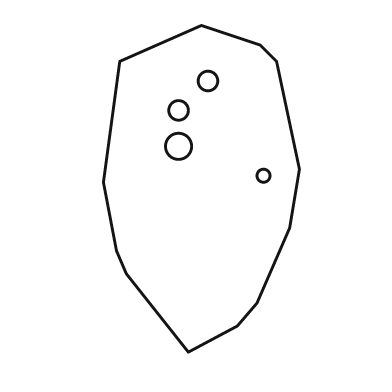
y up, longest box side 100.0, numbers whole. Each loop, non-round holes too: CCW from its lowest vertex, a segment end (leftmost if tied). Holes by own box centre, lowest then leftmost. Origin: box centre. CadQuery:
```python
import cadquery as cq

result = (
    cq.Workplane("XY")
    .moveTo(-4.0, -50.0)
    .lineTo(11.0, -42.0)
    .lineTo(17.0, -35.0)
    .lineTo(27.0, -12.0)
    .lineTo(30.0, 6.0)
    .lineTo(23.0, 39.0)
    .lineTo(18.0, 44.0)
    .lineTo(0.0, 50.0)
    .lineTo(-25.0, 39.0)
    .lineTo(-30.0, 2.0)
    .lineTo(-26.0, -19.0)
    .lineTo(-23.0, -26.0)
    .close()
    .moveTo(19.0, 4.0)
    .circle(2.0)
    .moveTo(-7.0, 13.0)
    .circle(4.0)
    .moveTo(-7.0, 24.0)
    .circle(3.0)
    .moveTo(2.0, 33.0)
    .circle(3.0)
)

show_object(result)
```